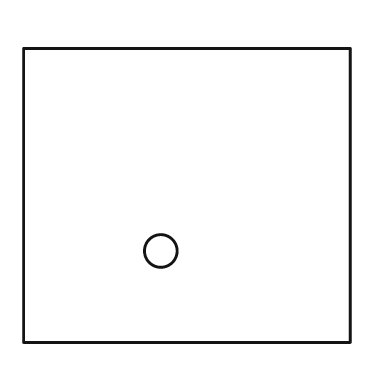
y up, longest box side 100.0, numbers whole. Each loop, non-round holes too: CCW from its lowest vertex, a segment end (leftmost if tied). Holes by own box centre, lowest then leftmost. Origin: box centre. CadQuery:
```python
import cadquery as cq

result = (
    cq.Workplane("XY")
    .moveTo(-50.0, -45.0)
    .lineTo(50.0, -45.0)
    .lineTo(50.0, 45.0)
    .lineTo(-50.0, 45.0)
    .close()
    .moveTo(-8.0, -17.0)
    .circle(5.0)
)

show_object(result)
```